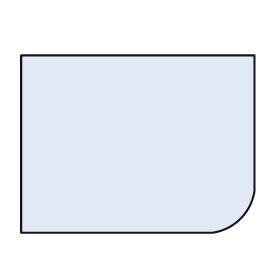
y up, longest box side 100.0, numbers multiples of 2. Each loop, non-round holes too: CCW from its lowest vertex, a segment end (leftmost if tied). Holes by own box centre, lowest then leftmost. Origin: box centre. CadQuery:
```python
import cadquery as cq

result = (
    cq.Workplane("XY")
    .moveTo(-50.0, -38.0)
    .lineTo(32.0, -38.0)
    .threePointArc((44.0, -32.0), (50.0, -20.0))
    .lineTo(50.0, 38.0)
    .lineTo(-50.0, 38.0)
    .close()
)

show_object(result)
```